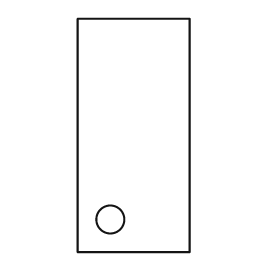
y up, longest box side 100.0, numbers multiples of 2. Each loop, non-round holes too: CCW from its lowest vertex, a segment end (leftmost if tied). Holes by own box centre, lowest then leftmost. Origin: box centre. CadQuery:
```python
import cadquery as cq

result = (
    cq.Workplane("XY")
    .moveTo(-24.0, -50.0)
    .lineTo(24.0, -50.0)
    .lineTo(24.0, 50.0)
    .lineTo(-24.0, 50.0)
    .close()
    .moveTo(-10.0, -36.0)
    .circle(6.0)
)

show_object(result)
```